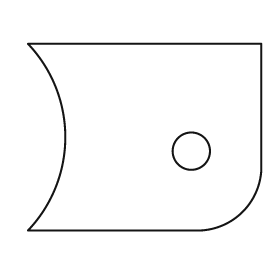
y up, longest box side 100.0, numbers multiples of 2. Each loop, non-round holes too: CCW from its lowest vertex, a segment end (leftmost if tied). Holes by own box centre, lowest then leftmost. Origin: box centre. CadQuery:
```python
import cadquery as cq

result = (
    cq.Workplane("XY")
    .moveTo(-50.0, -40.0)
    .lineTo(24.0, -40.0)
    .threePointArc((42.0, -32.0), (50.0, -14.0))
    .lineTo(50.0, 40.0)
    .lineTo(-50.0, 40.0)
    .threePointArc((-34.0, 0.0), (-50.0, -40.0))
    .close()
    .moveTo(20.0, -6.0)
    .circle(8.0)
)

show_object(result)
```